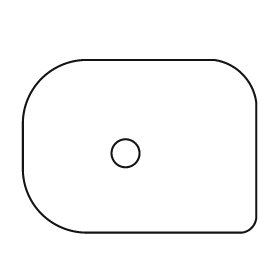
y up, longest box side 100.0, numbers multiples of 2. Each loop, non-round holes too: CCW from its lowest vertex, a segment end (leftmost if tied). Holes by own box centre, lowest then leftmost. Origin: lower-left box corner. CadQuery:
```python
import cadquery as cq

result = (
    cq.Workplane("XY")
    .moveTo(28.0, 0.0)
    .lineTo(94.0, 0.0)
    .threePointArc((98.0, 2.0), (100.0, 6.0))
    .lineTo(100.0, 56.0)
    .threePointArc((94.0, 68.0), (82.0, 74.0))
    .lineTo(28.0, 74.0)
    .threePointArc((8.0, 66.0), (0.0, 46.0))
    .lineTo(0.0, 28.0)
    .threePointArc((8.0, 8.0), (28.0, 0.0))
    .close()
    .moveTo(44.0, 34.0)
    .circle(6.0)
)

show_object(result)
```